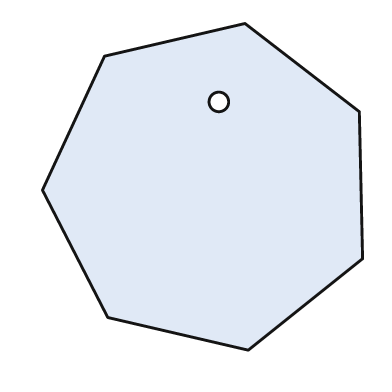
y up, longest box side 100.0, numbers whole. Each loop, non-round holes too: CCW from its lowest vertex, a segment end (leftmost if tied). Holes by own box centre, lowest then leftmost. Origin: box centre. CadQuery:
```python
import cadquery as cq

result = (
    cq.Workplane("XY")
    .moveTo(14.0, -50.0)
    .lineTo(49.0, -22.0)
    .lineTo(48.0, 23.0)
    .lineTo(13.0, 50.0)
    .lineTo(-30.0, 40.0)
    .lineTo(-49.0, -1.0)
    .lineTo(-29.0, -40.0)
    .close()
    .moveTo(5.0, 26.0)
    .circle(3.0)
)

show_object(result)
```